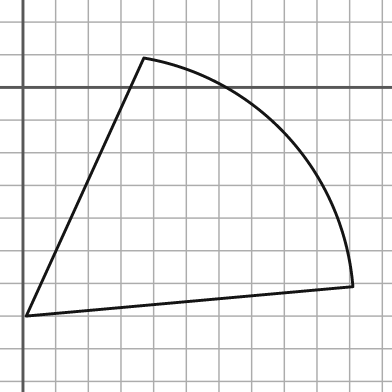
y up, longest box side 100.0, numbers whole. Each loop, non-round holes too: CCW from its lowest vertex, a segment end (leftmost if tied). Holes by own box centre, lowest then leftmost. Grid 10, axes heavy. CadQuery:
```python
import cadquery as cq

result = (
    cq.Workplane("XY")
    .moveTo(1.0, -70.0)
    .lineTo(101.0, -61.0)
    .threePointArc((81.0, -15.0), (37.0, 9.0))
    .close()
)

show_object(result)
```